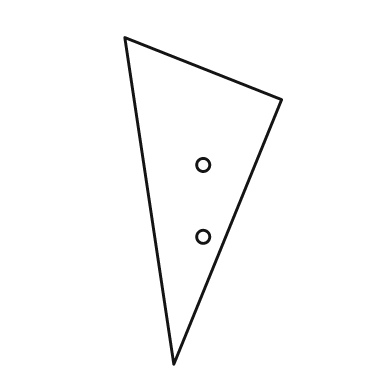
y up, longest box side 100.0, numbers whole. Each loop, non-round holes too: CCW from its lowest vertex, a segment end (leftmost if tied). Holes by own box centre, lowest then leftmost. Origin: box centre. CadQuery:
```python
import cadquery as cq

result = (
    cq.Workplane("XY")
    .moveTo(-9.0, -50.0)
    .lineTo(24.0, 31.0)
    .lineTo(-24.0, 50.0)
    .close()
    .moveTo(0.0, -11.0)
    .circle(2.0)
    .moveTo(0.0, 11.0)
    .circle(2.0)
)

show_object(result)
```